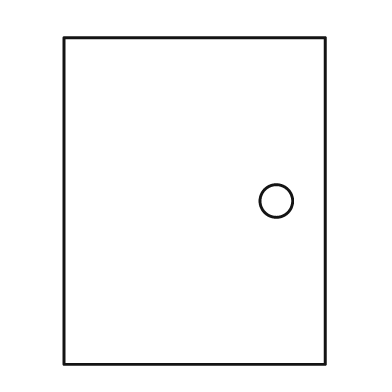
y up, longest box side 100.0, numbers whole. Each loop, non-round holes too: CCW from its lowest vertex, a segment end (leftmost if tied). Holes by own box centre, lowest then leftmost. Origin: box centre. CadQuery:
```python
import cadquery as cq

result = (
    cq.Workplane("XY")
    .moveTo(-40.0, -50.0)
    .lineTo(40.0, -50.0)
    .lineTo(40.0, 50.0)
    .lineTo(-40.0, 50.0)
    .close()
    .moveTo(25.0, 0.0)
    .circle(5.0)
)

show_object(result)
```